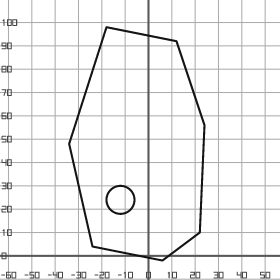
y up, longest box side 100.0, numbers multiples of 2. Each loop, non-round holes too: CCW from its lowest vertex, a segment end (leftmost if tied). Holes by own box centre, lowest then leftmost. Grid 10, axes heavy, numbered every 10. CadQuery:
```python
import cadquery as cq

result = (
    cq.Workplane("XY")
    .moveTo(6.0, -2.0)
    .lineTo(22.0, 10.0)
    .lineTo(24.0, 56.0)
    .lineTo(12.0, 92.0)
    .lineTo(-18.0, 98.0)
    .lineTo(-34.0, 48.0)
    .lineTo(-24.0, 4.0)
    .close()
    .moveTo(-12.0, 24.0)
    .circle(6.0)
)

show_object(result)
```